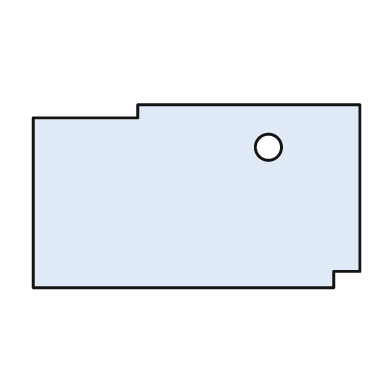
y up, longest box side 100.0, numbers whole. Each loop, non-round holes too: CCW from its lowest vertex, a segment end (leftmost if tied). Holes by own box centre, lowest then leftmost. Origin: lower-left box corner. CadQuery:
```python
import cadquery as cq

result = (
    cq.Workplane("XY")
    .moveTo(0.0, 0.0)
    .lineTo(92.0, 0.0)
    .lineTo(92.0, 5.0)
    .lineTo(100.0, 5.0)
    .lineTo(100.0, 56.0)
    .lineTo(32.0, 56.0)
    .lineTo(32.0, 52.0)
    .lineTo(0.0, 52.0)
    .close()
    .moveTo(72.0, 43.0)
    .circle(4.0)
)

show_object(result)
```